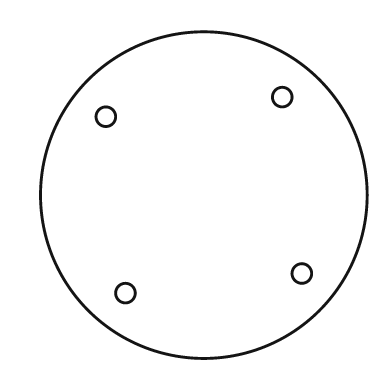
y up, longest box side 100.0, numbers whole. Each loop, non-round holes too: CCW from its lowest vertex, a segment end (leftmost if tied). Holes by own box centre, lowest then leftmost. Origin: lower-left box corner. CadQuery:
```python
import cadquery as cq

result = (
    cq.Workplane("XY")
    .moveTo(50.0, 50.0)
    .circle(50.0)
    .moveTo(26.0, 20.0)
    .circle(3.0)
    .moveTo(80.0, 26.0)
    .circle(3.0)
    .moveTo(20.0, 74.0)
    .circle(3.0)
    .moveTo(74.0, 80.0)
    .circle(3.0)
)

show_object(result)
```